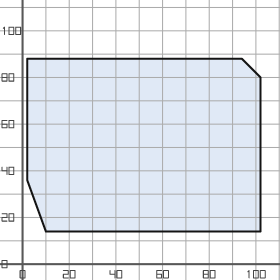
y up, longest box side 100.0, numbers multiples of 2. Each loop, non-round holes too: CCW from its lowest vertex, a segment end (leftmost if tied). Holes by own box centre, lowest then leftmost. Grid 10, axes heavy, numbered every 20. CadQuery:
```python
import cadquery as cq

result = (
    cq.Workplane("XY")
    .moveTo(10.0, 14.0)
    .lineTo(102.0, 14.0)
    .lineTo(102.0, 80.0)
    .lineTo(94.0, 88.0)
    .lineTo(2.0, 88.0)
    .lineTo(2.0, 36.0)
    .close()
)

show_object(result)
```